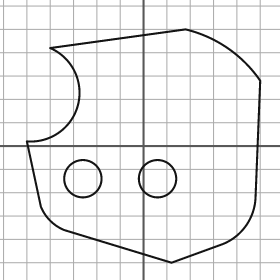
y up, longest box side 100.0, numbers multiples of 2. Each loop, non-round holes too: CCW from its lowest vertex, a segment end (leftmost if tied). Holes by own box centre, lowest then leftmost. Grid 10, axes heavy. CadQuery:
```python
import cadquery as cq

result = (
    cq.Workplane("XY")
    .moveTo(12.0, -50.0)
    .lineTo(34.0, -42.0)
    .threePointArc((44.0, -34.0), (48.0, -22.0))
    .lineTo(50.0, 28.0)
    .threePointArc((36.0, 42.0), (18.0, 50.0))
    .lineTo(-40.0, 42.0)
    .threePointArc((-28.0, 18.0), (-50.0, 2.0))
    .lineTo(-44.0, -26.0)
    .threePointArc((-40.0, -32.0), (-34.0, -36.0))
    .close()
    .moveTo(-26.0, -14.0)
    .circle(8.0)
    .moveTo(6.0, -14.0)
    .circle(8.0)
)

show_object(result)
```